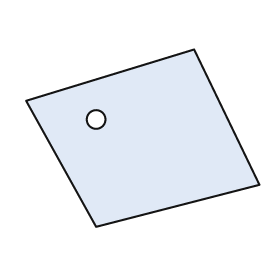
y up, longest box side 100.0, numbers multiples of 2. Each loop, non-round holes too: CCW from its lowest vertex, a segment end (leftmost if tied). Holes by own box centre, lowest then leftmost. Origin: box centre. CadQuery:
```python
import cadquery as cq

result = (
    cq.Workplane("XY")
    .moveTo(-20.0, -38.0)
    .lineTo(50.0, -20.0)
    .lineTo(22.0, 38.0)
    .lineTo(-50.0, 16.0)
    .close()
    .moveTo(-20.0, 8.0)
    .circle(4.0)
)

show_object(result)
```